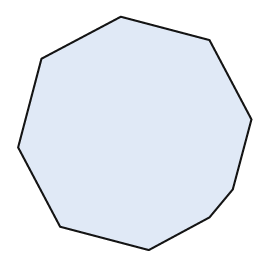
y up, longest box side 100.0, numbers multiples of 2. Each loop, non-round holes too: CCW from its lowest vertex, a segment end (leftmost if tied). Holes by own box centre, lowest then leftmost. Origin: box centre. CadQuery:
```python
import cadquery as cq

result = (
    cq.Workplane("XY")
    .moveTo(6.0, -50.0)
    .lineTo(32.0, -36.0)
    .lineTo(42.0, -24.0)
    .lineTo(50.0, 6.0)
    .lineTo(32.0, 40.0)
    .lineTo(-6.0, 50.0)
    .lineTo(-40.0, 32.0)
    .lineTo(-50.0, -6.0)
    .lineTo(-32.0, -40.0)
    .close()
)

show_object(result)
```